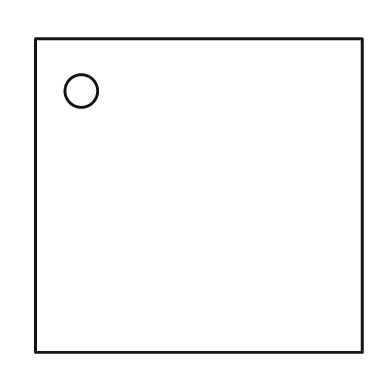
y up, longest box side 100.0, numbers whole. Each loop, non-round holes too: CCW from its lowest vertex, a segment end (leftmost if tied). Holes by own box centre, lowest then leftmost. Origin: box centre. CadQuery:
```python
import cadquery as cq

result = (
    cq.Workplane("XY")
    .moveTo(-50.0, -48.0)
    .lineTo(50.0, -48.0)
    .lineTo(50.0, 48.0)
    .lineTo(-50.0, 48.0)
    .close()
    .moveTo(-36.0, 32.0)
    .circle(5.0)
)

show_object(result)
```